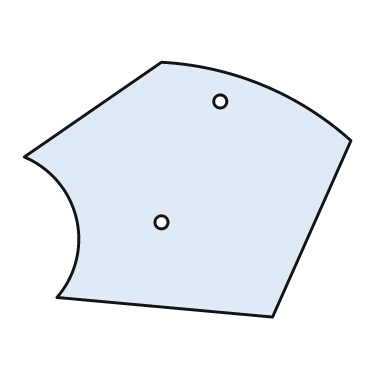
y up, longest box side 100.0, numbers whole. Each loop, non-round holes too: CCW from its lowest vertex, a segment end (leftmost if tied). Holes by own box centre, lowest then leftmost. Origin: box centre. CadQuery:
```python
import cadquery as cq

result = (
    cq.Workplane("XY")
    .moveTo(26.0, -39.0)
    .lineTo(50.0, 15.0)
    .threePointArc((23.0, 32.0), (-8.0, 39.0))
    .lineTo(-50.0, 10.0)
    .threePointArc((-34.0, -9.0), (-40.0, -33.0))
    .close()
    .moveTo(-8.0, -10.0)
    .circle(2.0)
    .moveTo(10.0, 27.0)
    .circle(2.0)
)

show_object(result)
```